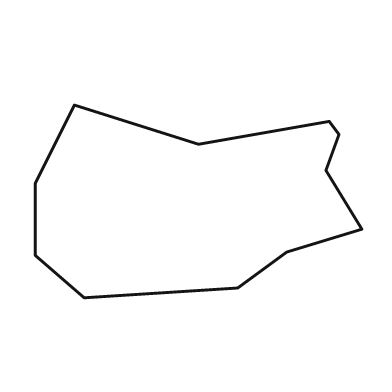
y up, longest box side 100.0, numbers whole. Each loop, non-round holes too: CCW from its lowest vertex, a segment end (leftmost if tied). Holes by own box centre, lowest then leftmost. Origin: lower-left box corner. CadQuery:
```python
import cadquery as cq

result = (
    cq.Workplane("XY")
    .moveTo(15.0, 0.0)
    .lineTo(62.0, 3.0)
    .lineTo(77.0, 14.0)
    .lineTo(100.0, 21.0)
    .lineTo(89.0, 39.0)
    .lineTo(93.0, 50.0)
    .lineTo(90.0, 54.0)
    .lineTo(50.0, 47.0)
    .lineTo(12.0, 59.0)
    .lineTo(0.0, 35.0)
    .lineTo(0.0, 13.0)
    .close()
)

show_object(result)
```